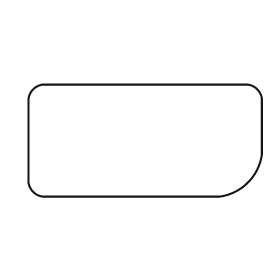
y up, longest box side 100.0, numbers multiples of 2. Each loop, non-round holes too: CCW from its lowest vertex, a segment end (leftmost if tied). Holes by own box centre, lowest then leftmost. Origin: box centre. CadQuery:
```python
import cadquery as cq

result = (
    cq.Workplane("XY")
    .moveTo(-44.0, -24.0)
    .lineTo(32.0, -24.0)
    .threePointArc((44.0, -18.0), (50.0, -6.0))
    .lineTo(50.0, 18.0)
    .threePointArc((48.0, 22.0), (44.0, 24.0))
    .lineTo(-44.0, 24.0)
    .threePointArc((-48.0, 22.0), (-50.0, 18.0))
    .lineTo(-50.0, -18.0)
    .threePointArc((-48.0, -22.0), (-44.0, -24.0))
    .close()
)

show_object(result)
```